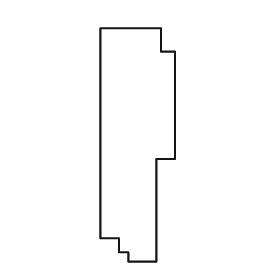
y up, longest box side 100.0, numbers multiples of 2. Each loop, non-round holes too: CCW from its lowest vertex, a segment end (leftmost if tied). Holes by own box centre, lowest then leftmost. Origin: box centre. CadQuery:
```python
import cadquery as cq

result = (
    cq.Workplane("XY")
    .moveTo(-4.0, -50.0)
    .lineTo(8.0, -50.0)
    .lineTo(8.0, -6.0)
    .lineTo(16.0, -6.0)
    .lineTo(16.0, 40.0)
    .lineTo(10.0, 40.0)
    .lineTo(10.0, 50.0)
    .lineTo(-16.0, 50.0)
    .lineTo(-16.0, -40.0)
    .lineTo(-8.0, -40.0)
    .lineTo(-8.0, -46.0)
    .lineTo(-4.0, -46.0)
    .close()
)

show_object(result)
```